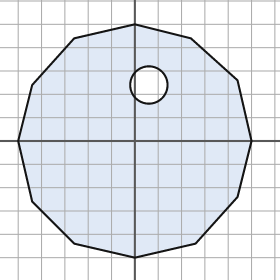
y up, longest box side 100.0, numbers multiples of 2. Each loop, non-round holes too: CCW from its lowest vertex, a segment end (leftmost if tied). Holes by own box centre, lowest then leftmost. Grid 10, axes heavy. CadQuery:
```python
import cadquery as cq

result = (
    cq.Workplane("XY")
    .moveTo(0.0, -50.0)
    .lineTo(26.0, -44.0)
    .lineTo(44.0, -24.0)
    .lineTo(50.0, 0.0)
    .lineTo(44.0, 26.0)
    .lineTo(24.0, 44.0)
    .lineTo(0.0, 50.0)
    .lineTo(-26.0, 44.0)
    .lineTo(-44.0, 24.0)
    .lineTo(-50.0, 0.0)
    .lineTo(-44.0, -26.0)
    .lineTo(-26.0, -44.0)
    .close()
    .moveTo(6.0, 24.0)
    .circle(8.0)
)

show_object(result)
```